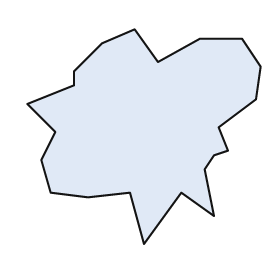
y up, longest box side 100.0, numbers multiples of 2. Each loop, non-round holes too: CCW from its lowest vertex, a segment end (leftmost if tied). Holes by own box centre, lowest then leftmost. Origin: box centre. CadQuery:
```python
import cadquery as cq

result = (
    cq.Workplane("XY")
    .moveTo(0.0, -46.0)
    .lineTo(16.0, -24.0)
    .lineTo(30.0, -34.0)
    .lineTo(26.0, -14.0)
    .lineTo(30.0, -8.0)
    .lineTo(36.0, -6.0)
    .lineTo(32.0, 4.0)
    .lineTo(48.0, 16.0)
    .lineTo(50.0, 30.0)
    .lineTo(42.0, 42.0)
    .lineTo(24.0, 42.0)
    .lineTo(6.0, 32.0)
    .lineTo(-4.0, 46.0)
    .lineTo(-18.0, 40.0)
    .lineTo(-30.0, 28.0)
    .lineTo(-30.0, 22.0)
    .lineTo(-50.0, 14.0)
    .lineTo(-38.0, 2.0)
    .lineTo(-44.0, -10.0)
    .lineTo(-40.0, -24.0)
    .lineTo(-24.0, -26.0)
    .lineTo(-6.0, -24.0)
    .close()
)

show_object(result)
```